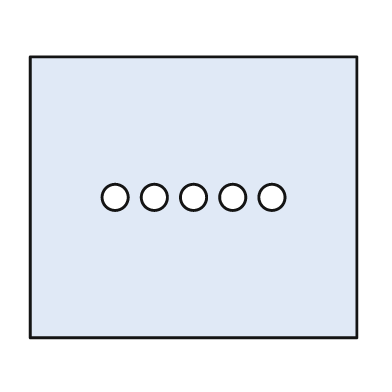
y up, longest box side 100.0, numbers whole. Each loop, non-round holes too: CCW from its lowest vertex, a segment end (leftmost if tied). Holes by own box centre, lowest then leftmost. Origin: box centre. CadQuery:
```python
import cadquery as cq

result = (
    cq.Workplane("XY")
    .moveTo(-50.0, -43.0)
    .lineTo(50.0, -43.0)
    .lineTo(50.0, 43.0)
    .lineTo(-50.0, 43.0)
    .close()
    .moveTo(-24.0, 0.0)
    .circle(4.0)
    .moveTo(-12.0, 0.0)
    .circle(4.0)
    .moveTo(0.0, 0.0)
    .circle(4.0)
    .moveTo(12.0, 0.0)
    .circle(4.0)
    .moveTo(24.0, 0.0)
    .circle(4.0)
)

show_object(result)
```